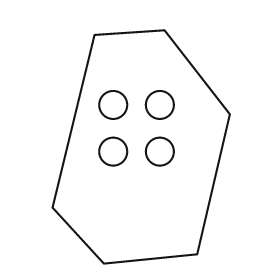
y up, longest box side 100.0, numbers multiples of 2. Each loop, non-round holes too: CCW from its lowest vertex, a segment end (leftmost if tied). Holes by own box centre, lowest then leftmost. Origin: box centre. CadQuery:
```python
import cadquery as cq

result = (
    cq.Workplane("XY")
    .moveTo(-16.0, -50.0)
    .lineTo(24.0, -46.0)
    .lineTo(38.0, 14.0)
    .lineTo(10.0, 50.0)
    .lineTo(-20.0, 48.0)
    .lineTo(-38.0, -26.0)
    .close()
    .moveTo(-12.0, -2.0)
    .circle(6.0)
    .moveTo(8.0, -2.0)
    .circle(6.0)
    .moveTo(-12.0, 18.0)
    .circle(6.0)
    .moveTo(8.0, 18.0)
    .circle(6.0)
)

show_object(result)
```